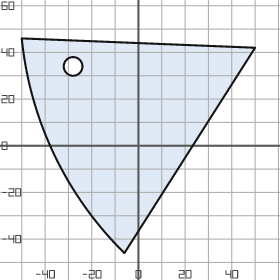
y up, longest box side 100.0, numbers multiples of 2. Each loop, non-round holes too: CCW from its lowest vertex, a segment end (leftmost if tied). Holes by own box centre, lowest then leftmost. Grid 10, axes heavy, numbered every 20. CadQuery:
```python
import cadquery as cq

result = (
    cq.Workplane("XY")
    .moveTo(-6.0, -46.0)
    .lineTo(50.0, 42.0)
    .lineTo(-50.0, 46.0)
    .threePointArc((-36.0, -4.0), (-6.0, -46.0))
    .close()
    .moveTo(-28.0, 34.0)
    .circle(4.0)
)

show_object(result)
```